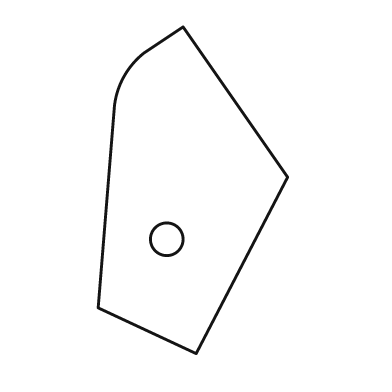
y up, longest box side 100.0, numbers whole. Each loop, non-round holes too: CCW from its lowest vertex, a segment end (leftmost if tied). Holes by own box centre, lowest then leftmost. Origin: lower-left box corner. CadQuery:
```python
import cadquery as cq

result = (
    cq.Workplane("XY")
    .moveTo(30.0, 0.0)
    .lineTo(58.0, 54.0)
    .lineTo(26.0, 100.0)
    .lineTo(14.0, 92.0)
    .threePointArc((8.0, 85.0), (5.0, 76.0))
    .lineTo(0.0, 14.0)
    .close()
    .moveTo(21.0, 35.0)
    .circle(5.0)
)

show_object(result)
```